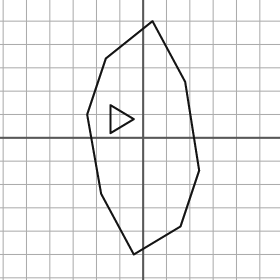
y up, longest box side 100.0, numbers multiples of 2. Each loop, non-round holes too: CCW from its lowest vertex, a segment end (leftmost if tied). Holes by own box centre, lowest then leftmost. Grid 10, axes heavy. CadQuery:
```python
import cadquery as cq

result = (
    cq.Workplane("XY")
    .moveTo(-4.0, -50.0)
    .lineTo(16.0, -38.0)
    .lineTo(24.0, -14.0)
    .lineTo(18.0, 24.0)
    .lineTo(4.0, 50.0)
    .lineTo(-16.0, 34.0)
    .lineTo(-24.0, 10.0)
    .lineTo(-18.0, -24.0)
    .close()
    .moveTo(-14.0, 2.0)
    .lineTo(-4.0, 8.0)
    .lineTo(-14.0, 14.0)
    .close()
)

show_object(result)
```